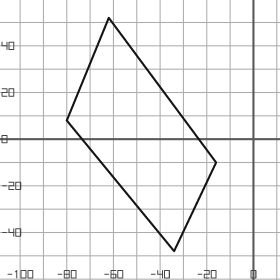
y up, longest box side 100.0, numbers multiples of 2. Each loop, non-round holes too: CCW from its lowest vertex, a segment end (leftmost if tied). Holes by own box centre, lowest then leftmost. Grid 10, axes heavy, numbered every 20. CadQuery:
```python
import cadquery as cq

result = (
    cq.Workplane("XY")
    .moveTo(-34.0, -48.0)
    .lineTo(-16.0, -10.0)
    .lineTo(-62.0, 52.0)
    .lineTo(-80.0, 8.0)
    .close()
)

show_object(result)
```